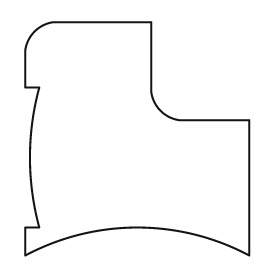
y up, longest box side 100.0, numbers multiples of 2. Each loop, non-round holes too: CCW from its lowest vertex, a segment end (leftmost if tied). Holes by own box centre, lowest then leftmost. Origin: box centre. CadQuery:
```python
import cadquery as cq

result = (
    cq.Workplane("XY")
    .moveTo(-48.0, -50.0)
    .threePointArc((0.0, -38.0), (48.0, -50.0))
    .lineTo(48.0, 8.0)
    .lineTo(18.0, 8.0)
    .threePointArc((10.0, 12.0), (6.0, 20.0))
    .lineTo(6.0, 50.0)
    .lineTo(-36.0, 50.0)
    .threePointArc((-44.0, 46.0), (-48.0, 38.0))
    .lineTo(-48.0, 22.0)
    .lineTo(-42.0, 22.0)
    .threePointArc((-46.0, -8.0), (-42.0, -38.0))
    .lineTo(-48.0, -38.0)
    .close()
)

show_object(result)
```